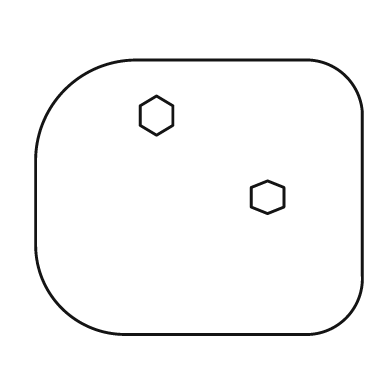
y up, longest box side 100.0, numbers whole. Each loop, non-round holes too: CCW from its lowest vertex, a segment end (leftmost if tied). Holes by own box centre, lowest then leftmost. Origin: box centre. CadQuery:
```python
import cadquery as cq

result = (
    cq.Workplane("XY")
    .moveTo(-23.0, -42.0)
    .lineTo(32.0, -42.0)
    .threePointArc((45.0, -37.0), (50.0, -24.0))
    .lineTo(50.0, 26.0)
    .threePointArc((45.0, 37.0), (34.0, 42.0))
    .lineTo(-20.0, 42.0)
    .threePointArc((-41.0, 33.0), (-50.0, 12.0))
    .lineTo(-50.0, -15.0)
    .threePointArc((-42.0, -34.0), (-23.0, -42.0))
    .close()
    .moveTo(21.0, -5.0)
    .lineTo(26.0, -3.0)
    .lineTo(26.0, 3.0)
    .lineTo(21.0, 5.0)
    .lineTo(16.0, 3.0)
    .lineTo(16.0, -3.0)
    .close()
    .moveTo(-13.0, 19.0)
    .lineTo(-8.0, 22.0)
    .lineTo(-8.0, 28.0)
    .lineTo(-13.0, 31.0)
    .lineTo(-18.0, 28.0)
    .lineTo(-18.0, 22.0)
    .close()
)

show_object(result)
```